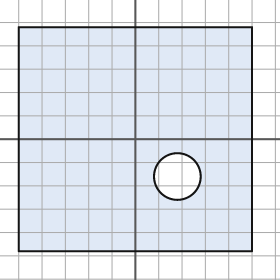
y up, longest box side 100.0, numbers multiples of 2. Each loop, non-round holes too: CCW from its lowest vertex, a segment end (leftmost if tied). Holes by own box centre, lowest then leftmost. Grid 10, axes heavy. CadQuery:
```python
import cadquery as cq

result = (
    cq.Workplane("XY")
    .moveTo(-50.0, -48.0)
    .lineTo(50.0, -48.0)
    .lineTo(50.0, 48.0)
    .lineTo(-50.0, 48.0)
    .close()
    .moveTo(18.0, -16.0)
    .circle(10.0)
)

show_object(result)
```